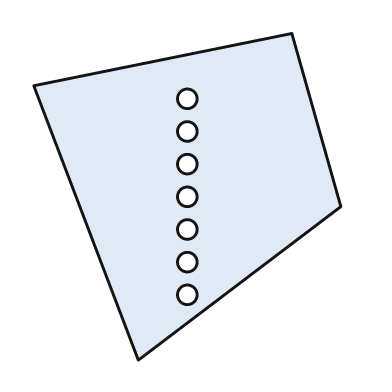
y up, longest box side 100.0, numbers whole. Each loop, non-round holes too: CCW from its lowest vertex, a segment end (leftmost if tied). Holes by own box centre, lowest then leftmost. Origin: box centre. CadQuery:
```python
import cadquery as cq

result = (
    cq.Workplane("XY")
    .moveTo(-15.0, -50.0)
    .lineTo(47.0, -3.0)
    .lineTo(32.0, 50.0)
    .lineTo(-47.0, 34.0)
    .close()
    .moveTo(0.0, -30.0)
    .circle(3.0)
    .moveTo(0.0, -20.0)
    .circle(3.0)
    .moveTo(0.0, -10.0)
    .circle(3.0)
    .moveTo(0.0, 0.0)
    .circle(3.0)
    .moveTo(0.0, 10.0)
    .circle(3.0)
    .moveTo(0.0, 20.0)
    .circle(3.0)
    .moveTo(0.0, 30.0)
    .circle(3.0)
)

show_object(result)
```